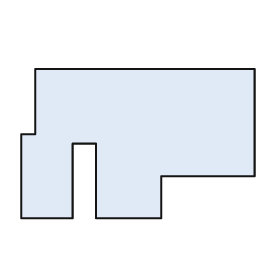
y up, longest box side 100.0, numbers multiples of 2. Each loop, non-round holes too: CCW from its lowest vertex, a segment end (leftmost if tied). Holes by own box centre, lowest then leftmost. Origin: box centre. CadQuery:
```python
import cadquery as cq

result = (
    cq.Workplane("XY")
    .moveTo(-50.0, -32.0)
    .lineTo(-28.0, -32.0)
    .lineTo(-28.0, 0.0)
    .lineTo(-18.0, 0.0)
    .lineTo(-18.0, -32.0)
    .lineTo(10.0, -32.0)
    .lineTo(10.0, -14.0)
    .lineTo(50.0, -14.0)
    .lineTo(50.0, 32.0)
    .lineTo(-44.0, 32.0)
    .lineTo(-44.0, 4.0)
    .lineTo(-50.0, 4.0)
    .close()
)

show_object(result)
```